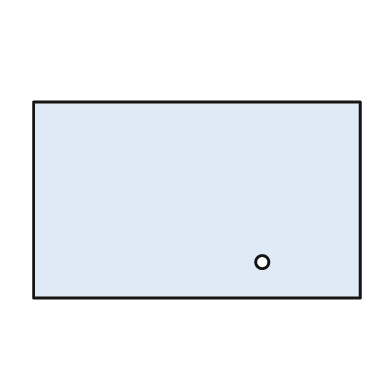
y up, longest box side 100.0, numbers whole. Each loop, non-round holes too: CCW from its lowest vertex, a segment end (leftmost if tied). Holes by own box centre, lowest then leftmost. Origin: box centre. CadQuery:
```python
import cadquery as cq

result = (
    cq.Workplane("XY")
    .moveTo(-50.0, -30.0)
    .lineTo(50.0, -30.0)
    .lineTo(50.0, 30.0)
    .lineTo(-50.0, 30.0)
    .close()
    .moveTo(20.0, -19.0)
    .circle(2.0)
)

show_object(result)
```